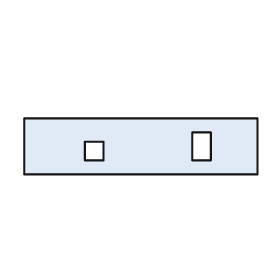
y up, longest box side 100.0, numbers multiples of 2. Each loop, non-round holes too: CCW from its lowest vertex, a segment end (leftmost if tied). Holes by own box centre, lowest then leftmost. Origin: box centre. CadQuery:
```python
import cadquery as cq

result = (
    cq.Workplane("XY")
    .moveTo(-50.0, -12.0)
    .lineTo(50.0, -12.0)
    .lineTo(50.0, 12.0)
    .lineTo(-50.0, 12.0)
    .close()
    .moveTo(-24.0, -6.0)
    .lineTo(-16.0, -6.0)
    .lineTo(-16.0, 2.0)
    .lineTo(-24.0, 2.0)
    .close()
    .moveTo(22.0, -6.0)
    .lineTo(30.0, -6.0)
    .lineTo(30.0, 6.0)
    .lineTo(22.0, 6.0)
    .close()
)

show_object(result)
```